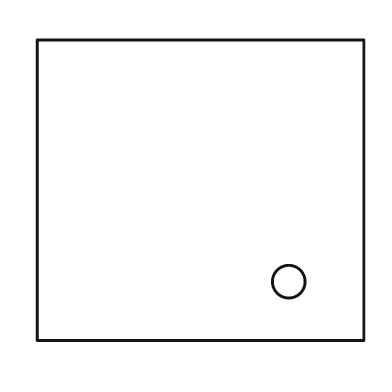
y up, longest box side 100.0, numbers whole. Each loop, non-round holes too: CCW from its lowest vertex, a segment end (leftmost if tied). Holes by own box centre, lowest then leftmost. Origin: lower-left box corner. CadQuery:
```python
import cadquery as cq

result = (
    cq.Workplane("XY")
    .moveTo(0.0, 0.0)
    .lineTo(100.0, 0.0)
    .lineTo(100.0, 92.0)
    .lineTo(0.0, 92.0)
    .close()
    .moveTo(77.0, 18.0)
    .circle(5.0)
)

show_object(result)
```